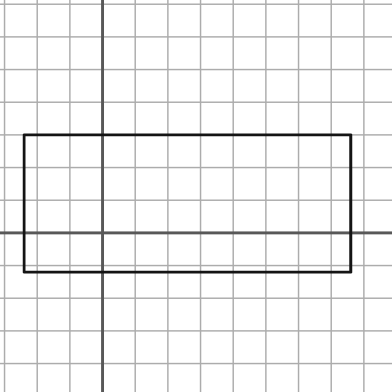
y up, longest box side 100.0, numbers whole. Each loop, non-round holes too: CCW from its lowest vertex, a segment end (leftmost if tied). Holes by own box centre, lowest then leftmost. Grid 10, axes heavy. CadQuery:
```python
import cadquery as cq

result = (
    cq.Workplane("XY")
    .moveTo(-24.0, -12.0)
    .lineTo(76.0, -12.0)
    .lineTo(76.0, 30.0)
    .lineTo(-24.0, 30.0)
    .close()
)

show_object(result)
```